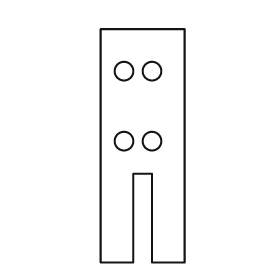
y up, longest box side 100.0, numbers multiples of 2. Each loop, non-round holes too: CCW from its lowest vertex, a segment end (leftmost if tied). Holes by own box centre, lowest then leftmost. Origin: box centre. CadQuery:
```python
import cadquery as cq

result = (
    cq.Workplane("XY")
    .moveTo(-18.0, -50.0)
    .lineTo(-4.0, -50.0)
    .lineTo(-4.0, -12.0)
    .lineTo(4.0, -12.0)
    .lineTo(4.0, -50.0)
    .lineTo(18.0, -50.0)
    .lineTo(18.0, 50.0)
    .lineTo(-18.0, 50.0)
    .close()
    .moveTo(-8.0, 2.0)
    .circle(4.0)
    .moveTo(4.0, 2.0)
    .circle(4.0)
    .moveTo(-8.0, 32.0)
    .circle(4.0)
    .moveTo(4.0, 32.0)
    .circle(4.0)
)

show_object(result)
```